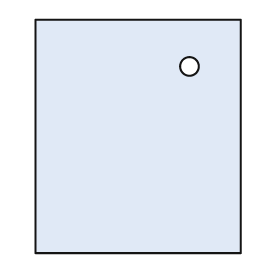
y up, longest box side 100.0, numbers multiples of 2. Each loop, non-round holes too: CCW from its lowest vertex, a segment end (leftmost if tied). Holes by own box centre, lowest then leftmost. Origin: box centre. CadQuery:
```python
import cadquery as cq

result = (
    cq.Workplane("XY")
    .moveTo(-44.0, -50.0)
    .lineTo(44.0, -50.0)
    .lineTo(44.0, 50.0)
    .lineTo(-44.0, 50.0)
    .close()
    .moveTo(22.0, 30.0)
    .circle(4.0)
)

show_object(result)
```